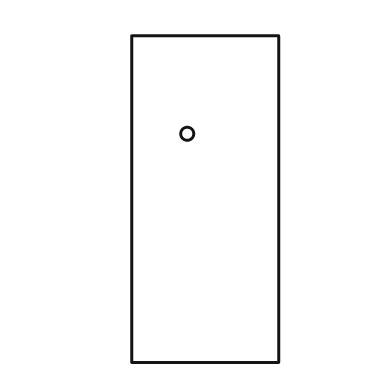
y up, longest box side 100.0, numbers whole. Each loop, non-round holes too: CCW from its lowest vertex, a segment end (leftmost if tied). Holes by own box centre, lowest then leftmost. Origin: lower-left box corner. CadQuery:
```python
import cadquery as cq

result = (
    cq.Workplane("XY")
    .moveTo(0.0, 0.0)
    .lineTo(45.0, 0.0)
    .lineTo(45.0, 100.0)
    .lineTo(0.0, 100.0)
    .close()
    .moveTo(17.0, 70.0)
    .circle(2.0)
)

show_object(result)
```